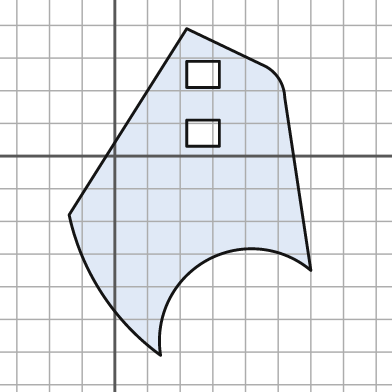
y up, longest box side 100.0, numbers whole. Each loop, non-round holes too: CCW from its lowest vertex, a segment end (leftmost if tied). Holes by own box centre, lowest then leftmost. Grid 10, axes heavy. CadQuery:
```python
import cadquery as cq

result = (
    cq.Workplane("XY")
    .moveTo(14.0, -61.0)
    .threePointArc((28.0, -32.0), (60.0, -35.0))
    .lineTo(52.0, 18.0)
    .threePointArc((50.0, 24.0), (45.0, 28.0))
    .lineTo(22.0, 39.0)
    .lineTo(-14.0, -18.0)
    .threePointArc((-4.0, -42.0), (14.0, -61.0))
    .close()
    .moveTo(22.0, 3.0)
    .lineTo(32.0, 3.0)
    .lineTo(32.0, 11.0)
    .lineTo(22.0, 11.0)
    .close()
    .moveTo(22.0, 21.0)
    .lineTo(32.0, 21.0)
    .lineTo(32.0, 29.0)
    .lineTo(22.0, 29.0)
    .close()
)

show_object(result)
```